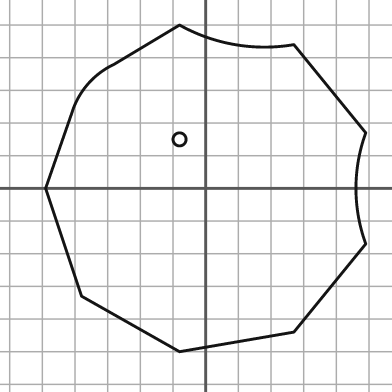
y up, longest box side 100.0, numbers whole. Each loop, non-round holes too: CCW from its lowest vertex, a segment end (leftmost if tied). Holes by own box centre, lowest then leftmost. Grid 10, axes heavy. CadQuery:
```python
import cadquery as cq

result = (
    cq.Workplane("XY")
    .moveTo(-8.0, -50.0)
    .lineTo(27.0, -44.0)
    .lineTo(49.0, -17.0)
    .threePointArc((46.0, 0.0), (49.0, 17.0))
    .lineTo(27.0, 44.0)
    .threePointArc((9.0, 44.0), (-8.0, 50.0))
    .lineTo(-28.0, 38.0)
    .threePointArc((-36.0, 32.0), (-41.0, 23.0))
    .lineTo(-49.0, 0.0)
    .lineTo(-38.0, -33.0)
    .close()
    .moveTo(-8.0, 15.0)
    .circle(2.0)
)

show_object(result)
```